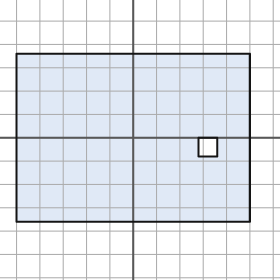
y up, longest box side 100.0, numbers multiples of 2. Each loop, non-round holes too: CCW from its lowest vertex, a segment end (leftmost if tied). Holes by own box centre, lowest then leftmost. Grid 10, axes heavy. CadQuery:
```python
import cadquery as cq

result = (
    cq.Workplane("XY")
    .moveTo(-50.0, -36.0)
    .lineTo(50.0, -36.0)
    .lineTo(50.0, 36.0)
    .lineTo(-50.0, 36.0)
    .close()
    .moveTo(28.0, -8.0)
    .lineTo(36.0, -8.0)
    .lineTo(36.0, 0.0)
    .lineTo(28.0, 0.0)
    .close()
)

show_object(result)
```